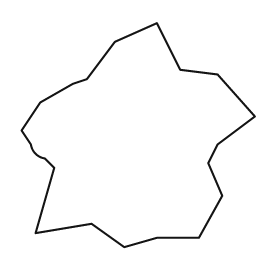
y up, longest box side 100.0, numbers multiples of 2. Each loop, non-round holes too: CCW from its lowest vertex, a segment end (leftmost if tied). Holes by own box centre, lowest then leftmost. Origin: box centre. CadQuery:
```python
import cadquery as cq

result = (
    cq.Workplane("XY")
    .moveTo(-6.0, -48.0)
    .lineTo(8.0, -44.0)
    .lineTo(26.0, -44.0)
    .lineTo(36.0, -26.0)
    .lineTo(30.0, -12.0)
    .lineTo(34.0, -4.0)
    .lineTo(50.0, 8.0)
    .lineTo(34.0, 26.0)
    .lineTo(18.0, 28.0)
    .lineTo(8.0, 48.0)
    .lineTo(-10.0, 40.0)
    .lineTo(-22.0, 24.0)
    .lineTo(-28.0, 22.0)
    .lineTo(-42.0, 14.0)
    .lineTo(-50.0, 2.0)
    .lineTo(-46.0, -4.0)
    .threePointArc((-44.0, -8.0), (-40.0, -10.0))
    .lineTo(-36.0, -14.0)
    .lineTo(-44.0, -42.0)
    .lineTo(-20.0, -38.0)
    .close()
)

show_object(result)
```